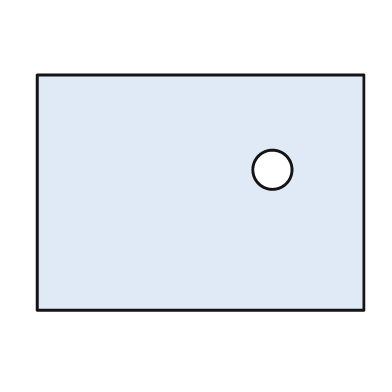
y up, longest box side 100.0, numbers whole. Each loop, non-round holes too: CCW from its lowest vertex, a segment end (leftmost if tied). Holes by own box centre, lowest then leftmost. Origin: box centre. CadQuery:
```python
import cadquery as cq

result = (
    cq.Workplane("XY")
    .moveTo(-50.0, -36.0)
    .lineTo(50.0, -36.0)
    .lineTo(50.0, 36.0)
    .lineTo(-50.0, 36.0)
    .close()
    .moveTo(22.0, 7.0)
    .circle(6.0)
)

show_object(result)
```